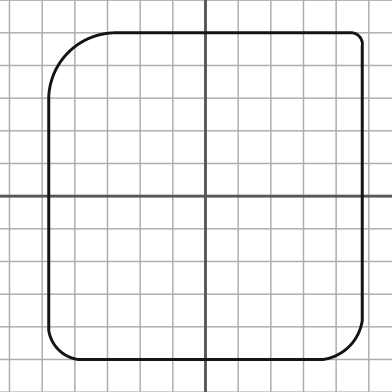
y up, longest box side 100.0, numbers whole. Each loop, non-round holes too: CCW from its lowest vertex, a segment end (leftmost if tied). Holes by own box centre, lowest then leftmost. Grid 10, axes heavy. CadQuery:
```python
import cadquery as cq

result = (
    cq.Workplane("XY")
    .moveTo(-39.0, -50.0)
    .lineTo(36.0, -50.0)
    .threePointArc((44.0, -46.0), (48.0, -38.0))
    .lineTo(48.0, 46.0)
    .threePointArc((47.0, 49.0), (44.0, 50.0))
    .lineTo(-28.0, 50.0)
    .threePointArc((-42.0, 44.0), (-48.0, 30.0))
    .lineTo(-48.0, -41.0)
    .threePointArc((-45.0, -47.0), (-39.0, -50.0))
    .close()
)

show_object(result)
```